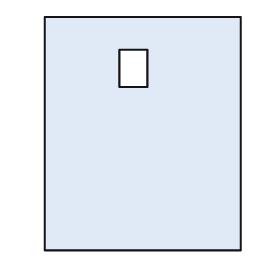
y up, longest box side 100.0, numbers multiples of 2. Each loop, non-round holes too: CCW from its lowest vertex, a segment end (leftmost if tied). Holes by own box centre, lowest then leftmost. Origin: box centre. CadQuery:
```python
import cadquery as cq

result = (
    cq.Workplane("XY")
    .moveTo(-42.0, -50.0)
    .lineTo(42.0, -50.0)
    .lineTo(42.0, 50.0)
    .lineTo(-42.0, 50.0)
    .close()
    .moveTo(-10.0, 20.0)
    .lineTo(2.0, 20.0)
    .lineTo(2.0, 36.0)
    .lineTo(-10.0, 36.0)
    .close()
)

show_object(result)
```